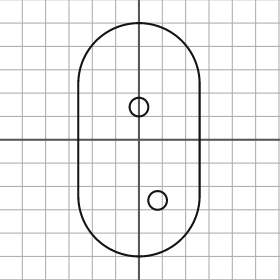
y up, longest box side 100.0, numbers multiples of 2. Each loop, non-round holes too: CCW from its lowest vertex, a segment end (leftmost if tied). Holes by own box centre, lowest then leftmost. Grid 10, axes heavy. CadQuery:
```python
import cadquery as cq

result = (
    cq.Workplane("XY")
    .moveTo(-26.0, -24.0)
    .threePointArc((0.0, -50.0), (26.0, -24.0))
    .lineTo(26.0, 24.0)
    .threePointArc((0.0, 50.0), (-26.0, 24.0))
    .close()
    .moveTo(8.0, -26.0)
    .circle(4.0)
    .moveTo(0.0, 14.0)
    .circle(4.0)
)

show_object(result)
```